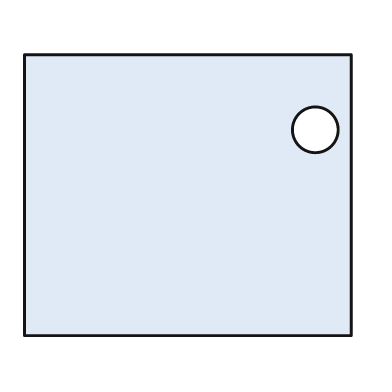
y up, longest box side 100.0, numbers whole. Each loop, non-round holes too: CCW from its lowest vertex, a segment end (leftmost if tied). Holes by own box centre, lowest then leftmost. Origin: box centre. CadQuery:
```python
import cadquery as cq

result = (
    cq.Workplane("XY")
    .moveTo(-50.0, -43.0)
    .lineTo(50.0, -43.0)
    .lineTo(50.0, 43.0)
    .lineTo(-50.0, 43.0)
    .close()
    .moveTo(39.0, 20.0)
    .circle(7.0)
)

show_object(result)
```